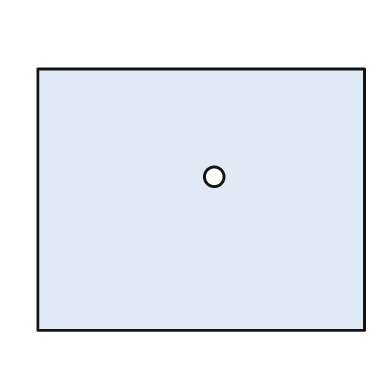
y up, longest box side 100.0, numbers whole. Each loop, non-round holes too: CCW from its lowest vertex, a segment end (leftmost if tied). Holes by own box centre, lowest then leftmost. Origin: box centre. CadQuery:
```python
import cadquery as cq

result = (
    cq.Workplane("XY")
    .moveTo(-50.0, -40.0)
    .lineTo(50.0, -40.0)
    .lineTo(50.0, 40.0)
    .lineTo(-50.0, 40.0)
    .close()
    .moveTo(4.0, 7.0)
    .circle(3.0)
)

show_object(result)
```